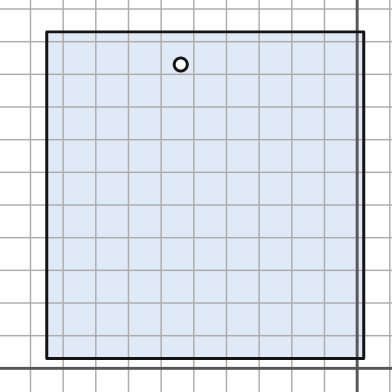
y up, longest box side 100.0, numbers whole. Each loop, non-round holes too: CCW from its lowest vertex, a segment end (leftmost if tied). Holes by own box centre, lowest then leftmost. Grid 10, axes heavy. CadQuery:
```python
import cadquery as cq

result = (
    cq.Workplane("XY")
    .moveTo(-95.0, 3.0)
    .lineTo(2.0, 3.0)
    .lineTo(2.0, 103.0)
    .lineTo(-95.0, 103.0)
    .close()
    .moveTo(-54.0, 93.0)
    .circle(2.0)
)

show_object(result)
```